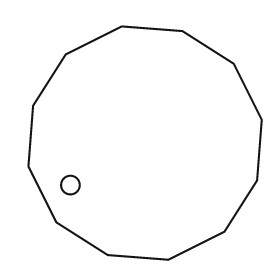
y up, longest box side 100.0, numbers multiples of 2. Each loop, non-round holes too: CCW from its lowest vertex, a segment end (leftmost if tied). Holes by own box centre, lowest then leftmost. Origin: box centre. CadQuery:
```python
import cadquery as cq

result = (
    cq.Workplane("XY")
    .moveTo(10.0, -50.0)
    .lineTo(34.0, -38.0)
    .lineTo(48.0, -16.0)
    .lineTo(50.0, 10.0)
    .lineTo(38.0, 34.0)
    .lineTo(16.0, 48.0)
    .lineTo(-10.0, 50.0)
    .lineTo(-34.0, 38.0)
    .lineTo(-48.0, 16.0)
    .lineTo(-50.0, -10.0)
    .lineTo(-38.0, -34.0)
    .lineTo(-16.0, -48.0)
    .close()
    .moveTo(-32.0, -18.0)
    .circle(4.0)
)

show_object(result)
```